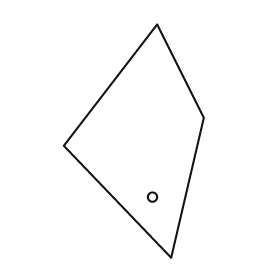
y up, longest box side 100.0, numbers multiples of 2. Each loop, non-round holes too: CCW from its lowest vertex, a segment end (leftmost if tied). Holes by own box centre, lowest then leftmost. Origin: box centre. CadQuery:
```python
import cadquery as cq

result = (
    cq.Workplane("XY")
    .moveTo(16.0, -50.0)
    .lineTo(30.0, 10.0)
    .lineTo(10.0, 50.0)
    .lineTo(-30.0, -2.0)
    .close()
    .moveTo(8.0, -24.0)
    .circle(2.0)
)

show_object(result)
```